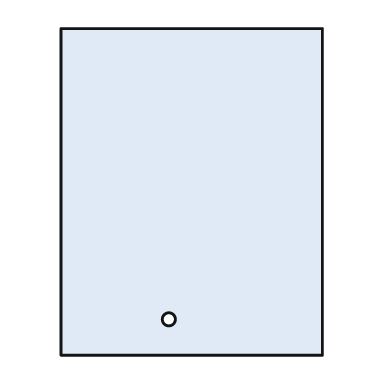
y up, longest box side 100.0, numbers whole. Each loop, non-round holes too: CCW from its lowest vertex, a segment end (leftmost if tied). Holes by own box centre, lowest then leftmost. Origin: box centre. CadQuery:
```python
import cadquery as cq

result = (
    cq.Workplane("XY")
    .moveTo(-40.0, -50.0)
    .lineTo(40.0, -50.0)
    .lineTo(40.0, 50.0)
    .lineTo(-40.0, 50.0)
    .close()
    .moveTo(-7.0, -39.0)
    .circle(2.0)
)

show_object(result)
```